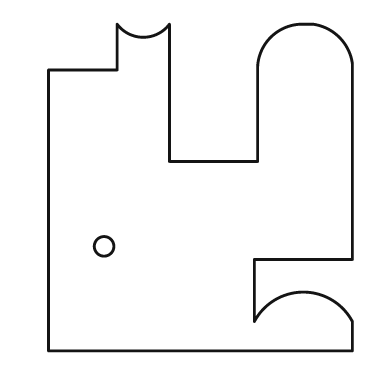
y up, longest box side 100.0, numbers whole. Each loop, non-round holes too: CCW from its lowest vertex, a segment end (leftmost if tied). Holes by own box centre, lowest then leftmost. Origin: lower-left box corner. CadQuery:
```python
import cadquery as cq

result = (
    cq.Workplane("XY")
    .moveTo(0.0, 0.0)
    .lineTo(93.0, 0.0)
    .lineTo(93.0, 9.0)
    .threePointArc((78.0, 18.0), (63.0, 9.0))
    .lineTo(63.0, 28.0)
    .lineTo(93.0, 28.0)
    .lineTo(93.0, 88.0)
    .threePointArc((89.0, 96.0), (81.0, 100.0))
    .lineTo(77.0, 100.0)
    .threePointArc((68.0, 96.0), (64.0, 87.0))
    .lineTo(64.0, 58.0)
    .lineTo(37.0, 58.0)
    .lineTo(37.0, 100.0)
    .threePointArc((29.0, 96.0), (21.0, 100.0))
    .lineTo(21.0, 86.0)
    .lineTo(0.0, 86.0)
    .close()
    .moveTo(17.0, 32.0)
    .circle(3.0)
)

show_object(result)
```